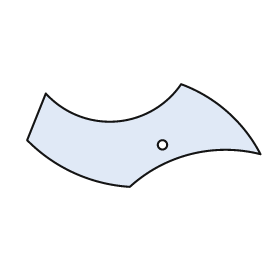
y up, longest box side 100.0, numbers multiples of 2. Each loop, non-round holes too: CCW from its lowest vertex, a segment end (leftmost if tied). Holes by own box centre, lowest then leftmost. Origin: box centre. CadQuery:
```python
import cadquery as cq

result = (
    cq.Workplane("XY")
    .moveTo(-6.0, -22.0)
    .threePointArc((20.0, -8.0), (50.0, -8.0))
    .threePointArc((36.0, 10.0), (16.0, 22.0))
    .threePointArc((-12.0, 6.0), (-42.0, 18.0))
    .lineTo(-50.0, -2.0)
    .threePointArc((-30.0, -16.0), (-6.0, -22.0))
    .close()
    .moveTo(8.0, -4.0)
    .circle(2.0)
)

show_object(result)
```